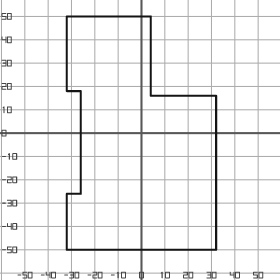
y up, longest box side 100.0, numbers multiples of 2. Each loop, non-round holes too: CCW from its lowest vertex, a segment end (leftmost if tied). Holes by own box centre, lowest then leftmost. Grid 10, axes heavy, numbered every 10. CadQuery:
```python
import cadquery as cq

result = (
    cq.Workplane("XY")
    .moveTo(-32.0, -50.0)
    .lineTo(32.0, -50.0)
    .lineTo(32.0, 16.0)
    .lineTo(4.0, 16.0)
    .lineTo(4.0, 50.0)
    .lineTo(-32.0, 50.0)
    .lineTo(-32.0, 18.0)
    .lineTo(-26.0, 18.0)
    .lineTo(-26.0, -26.0)
    .lineTo(-32.0, -26.0)
    .close()
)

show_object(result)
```